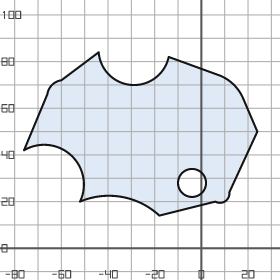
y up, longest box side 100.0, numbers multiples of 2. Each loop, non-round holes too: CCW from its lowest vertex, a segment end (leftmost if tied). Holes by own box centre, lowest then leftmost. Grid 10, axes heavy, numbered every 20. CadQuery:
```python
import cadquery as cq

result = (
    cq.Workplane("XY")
    .moveTo(-18.0, 14.0)
    .lineTo(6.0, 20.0)
    .threePointArc((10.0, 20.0), (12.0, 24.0))
    .lineTo(24.0, 50.0)
    .lineTo(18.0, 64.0)
    .threePointArc((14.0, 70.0), (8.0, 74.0))
    .lineTo(-14.0, 82.0)
    .threePointArc((-30.0, 70.0), (-44.0, 84.0))
    .lineTo(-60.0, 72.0)
    .threePointArc((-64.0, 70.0), (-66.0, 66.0))
    .lineTo(-76.0, 42.0)
    .threePointArc((-56.0, 40.0), (-52.0, 20.0))
    .threePointArc((-34.0, 22.0), (-18.0, 14.0))
    .close()
    .moveTo(-4.0, 28.0)
    .circle(6.0)
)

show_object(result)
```